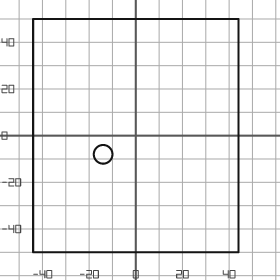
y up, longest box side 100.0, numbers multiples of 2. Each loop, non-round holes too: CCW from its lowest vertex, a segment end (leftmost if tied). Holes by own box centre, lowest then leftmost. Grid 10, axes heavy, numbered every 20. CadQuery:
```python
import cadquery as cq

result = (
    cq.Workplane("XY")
    .moveTo(-44.0, -50.0)
    .lineTo(44.0, -50.0)
    .lineTo(44.0, 50.0)
    .lineTo(-44.0, 50.0)
    .close()
    .moveTo(-14.0, -8.0)
    .circle(4.0)
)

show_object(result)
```